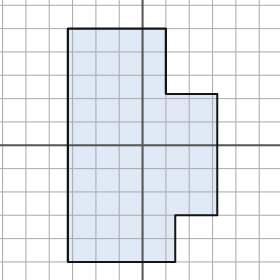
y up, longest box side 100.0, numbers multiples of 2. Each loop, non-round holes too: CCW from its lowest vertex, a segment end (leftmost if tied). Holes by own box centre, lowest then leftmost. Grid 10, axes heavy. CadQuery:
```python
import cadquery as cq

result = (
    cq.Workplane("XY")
    .moveTo(-32.0, -50.0)
    .lineTo(14.0, -50.0)
    .lineTo(14.0, -30.0)
    .lineTo(32.0, -30.0)
    .lineTo(32.0, 22.0)
    .lineTo(10.0, 22.0)
    .lineTo(10.0, 50.0)
    .lineTo(-32.0, 50.0)
    .close()
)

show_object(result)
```